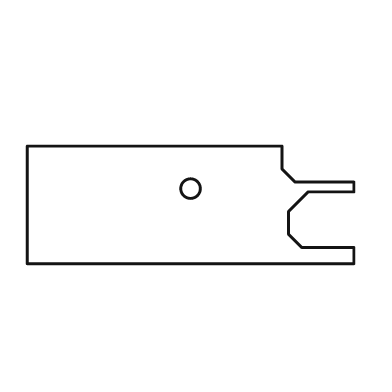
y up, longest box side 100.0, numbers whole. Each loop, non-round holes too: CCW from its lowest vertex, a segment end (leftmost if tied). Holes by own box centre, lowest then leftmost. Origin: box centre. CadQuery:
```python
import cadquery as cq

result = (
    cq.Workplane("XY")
    .moveTo(-50.0, -18.0)
    .lineTo(50.0, -18.0)
    .lineTo(50.0, -13.0)
    .lineTo(34.0, -13.0)
    .lineTo(30.0, -9.0)
    .lineTo(30.0, -2.0)
    .lineTo(36.0, 4.0)
    .lineTo(50.0, 4.0)
    .lineTo(50.0, 7.0)
    .lineTo(32.0, 7.0)
    .lineTo(28.0, 11.0)
    .lineTo(28.0, 18.0)
    .lineTo(-50.0, 18.0)
    .close()
    .moveTo(0.0, 5.0)
    .circle(3.0)
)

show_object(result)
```